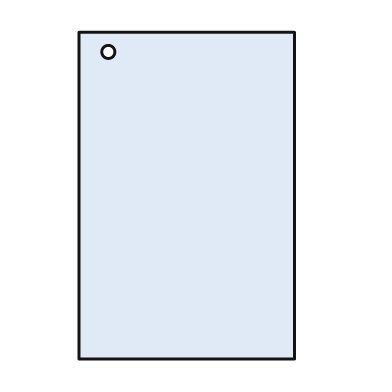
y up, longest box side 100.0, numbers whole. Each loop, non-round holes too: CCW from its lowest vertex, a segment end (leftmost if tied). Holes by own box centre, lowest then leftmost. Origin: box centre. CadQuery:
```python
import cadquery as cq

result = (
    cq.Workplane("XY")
    .moveTo(-33.0, -50.0)
    .lineTo(33.0, -50.0)
    .lineTo(33.0, 50.0)
    .lineTo(-33.0, 50.0)
    .close()
    .moveTo(-24.0, 44.0)
    .circle(2.0)
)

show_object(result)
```